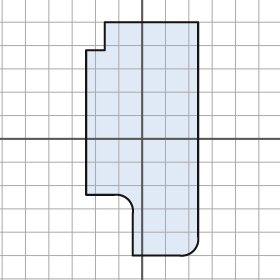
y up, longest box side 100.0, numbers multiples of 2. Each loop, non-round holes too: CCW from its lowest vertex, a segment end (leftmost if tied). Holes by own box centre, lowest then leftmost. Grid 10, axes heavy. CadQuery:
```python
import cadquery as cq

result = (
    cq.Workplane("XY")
    .moveTo(-4.0, -50.0)
    .lineTo(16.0, -50.0)
    .threePointArc((22.0, -48.0), (24.0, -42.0))
    .lineTo(24.0, 50.0)
    .lineTo(-16.0, 50.0)
    .lineTo(-16.0, 38.0)
    .lineTo(-24.0, 38.0)
    .lineTo(-24.0, -24.0)
    .lineTo(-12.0, -24.0)
    .threePointArc((-6.0, -26.0), (-4.0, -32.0))
    .close()
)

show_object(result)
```